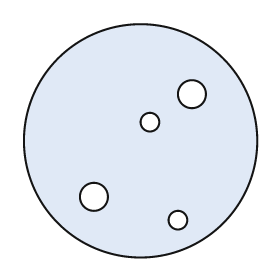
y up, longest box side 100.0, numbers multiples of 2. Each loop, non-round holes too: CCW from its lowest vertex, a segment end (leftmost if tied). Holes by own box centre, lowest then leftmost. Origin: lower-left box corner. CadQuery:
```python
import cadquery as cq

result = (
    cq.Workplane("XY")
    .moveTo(50.0, 50.0)
    .circle(50.0)
    .moveTo(66.0, 16.0)
    .circle(4.0)
    .moveTo(30.0, 26.0)
    .circle(6.0)
    .moveTo(54.0, 58.0)
    .circle(4.0)
    .moveTo(72.0, 70.0)
    .circle(6.0)
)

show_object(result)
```